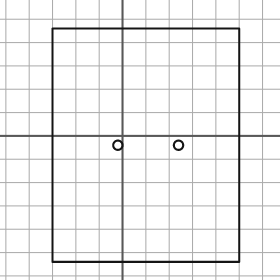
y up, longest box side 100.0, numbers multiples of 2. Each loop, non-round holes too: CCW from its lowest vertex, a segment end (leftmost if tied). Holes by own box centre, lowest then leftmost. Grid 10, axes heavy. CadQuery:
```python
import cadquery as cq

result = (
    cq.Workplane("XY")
    .moveTo(-30.0, -54.0)
    .lineTo(50.0, -54.0)
    .lineTo(50.0, 46.0)
    .lineTo(-30.0, 46.0)
    .close()
    .moveTo(-2.0, -4.0)
    .circle(2.0)
    .moveTo(24.0, -4.0)
    .circle(2.0)
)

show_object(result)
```